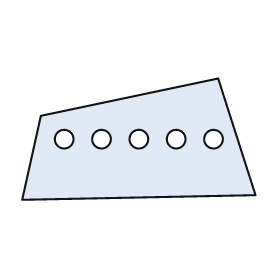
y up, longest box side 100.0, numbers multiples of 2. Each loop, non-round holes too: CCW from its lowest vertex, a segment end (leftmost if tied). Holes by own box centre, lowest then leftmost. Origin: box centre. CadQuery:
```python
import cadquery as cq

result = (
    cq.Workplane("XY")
    .moveTo(-50.0, -26.0)
    .lineTo(50.0, -24.0)
    .lineTo(34.0, 26.0)
    .lineTo(-42.0, 10.0)
    .close()
    .moveTo(-32.0, 0.0)
    .circle(4.0)
    .moveTo(-16.0, 0.0)
    .circle(4.0)
    .moveTo(0.0, 0.0)
    .circle(4.0)
    .moveTo(16.0, 0.0)
    .circle(4.0)
    .moveTo(32.0, 0.0)
    .circle(4.0)
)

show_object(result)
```